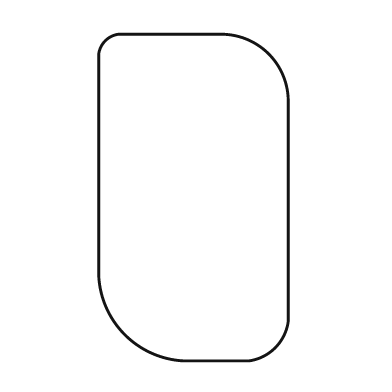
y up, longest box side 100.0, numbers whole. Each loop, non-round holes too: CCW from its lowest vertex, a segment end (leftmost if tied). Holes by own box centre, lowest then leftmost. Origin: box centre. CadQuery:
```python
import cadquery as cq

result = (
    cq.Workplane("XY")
    .moveTo(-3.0, -50.0)
    .lineTo(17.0, -50.0)
    .threePointArc((25.0, -46.0), (29.0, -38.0))
    .lineTo(29.0, 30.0)
    .threePointArc((23.0, 44.0), (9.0, 50.0))
    .lineTo(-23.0, 50.0)
    .threePointArc((-27.0, 48.0), (-29.0, 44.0))
    .lineTo(-29.0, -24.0)
    .threePointArc((-21.0, -42.0), (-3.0, -50.0))
    .close()
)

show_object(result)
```